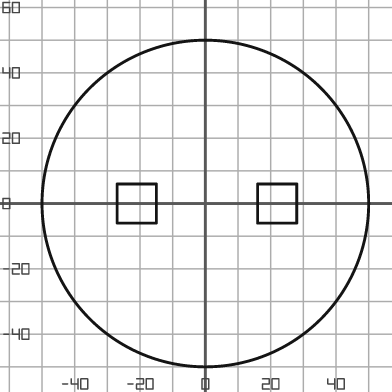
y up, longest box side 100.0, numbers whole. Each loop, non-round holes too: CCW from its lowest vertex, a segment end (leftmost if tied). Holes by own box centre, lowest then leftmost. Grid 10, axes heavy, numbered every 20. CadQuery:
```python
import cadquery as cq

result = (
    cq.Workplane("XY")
    .moveTo(0.0, 0.0)
    .circle(50.0)
    .moveTo(-27.0, -6.0)
    .lineTo(-15.0, -6.0)
    .lineTo(-15.0, 6.0)
    .lineTo(-27.0, 6.0)
    .close()
    .moveTo(16.0, -6.0)
    .lineTo(28.0, -6.0)
    .lineTo(28.0, 6.0)
    .lineTo(16.0, 6.0)
    .close()
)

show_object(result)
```